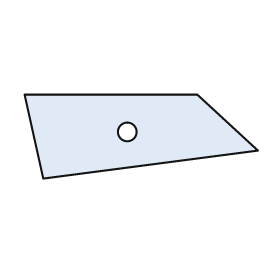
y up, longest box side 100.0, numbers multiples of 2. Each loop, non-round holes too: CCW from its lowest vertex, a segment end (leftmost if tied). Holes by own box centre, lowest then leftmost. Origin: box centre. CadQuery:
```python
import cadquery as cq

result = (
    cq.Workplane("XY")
    .moveTo(-42.0, -18.0)
    .lineTo(50.0, -6.0)
    .lineTo(24.0, 18.0)
    .lineTo(-50.0, 18.0)
    .close()
    .moveTo(-6.0, 2.0)
    .circle(4.0)
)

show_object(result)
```